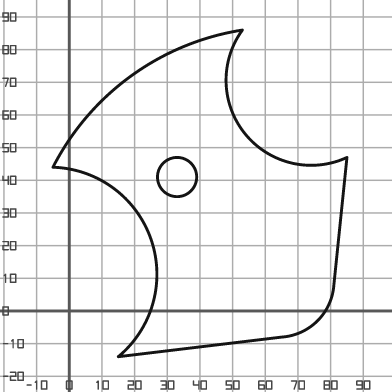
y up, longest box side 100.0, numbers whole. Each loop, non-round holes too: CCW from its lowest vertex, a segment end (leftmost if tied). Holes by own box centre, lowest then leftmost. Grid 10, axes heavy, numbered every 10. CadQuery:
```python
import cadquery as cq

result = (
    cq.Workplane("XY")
    .moveTo(15.0, -14.0)
    .lineTo(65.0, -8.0)
    .threePointArc((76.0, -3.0), (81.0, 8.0))
    .lineTo(85.0, 47.0)
    .threePointArc((54.0, 54.0), (53.0, 86.0))
    .threePointArc((19.0, 72.0), (-5.0, 44.0))
    .threePointArc((25.0, 22.0), (15.0, -14.0))
    .close()
    .moveTo(33.0, 41.0)
    .circle(6.0)
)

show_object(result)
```